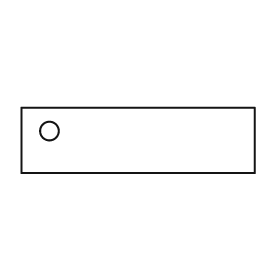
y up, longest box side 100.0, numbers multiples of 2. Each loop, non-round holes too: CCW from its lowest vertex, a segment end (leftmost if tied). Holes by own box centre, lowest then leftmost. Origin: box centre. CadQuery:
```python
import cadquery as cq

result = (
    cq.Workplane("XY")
    .moveTo(-50.0, -14.0)
    .lineTo(50.0, -14.0)
    .lineTo(50.0, 14.0)
    .lineTo(-50.0, 14.0)
    .close()
    .moveTo(-38.0, 4.0)
    .circle(4.0)
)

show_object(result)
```